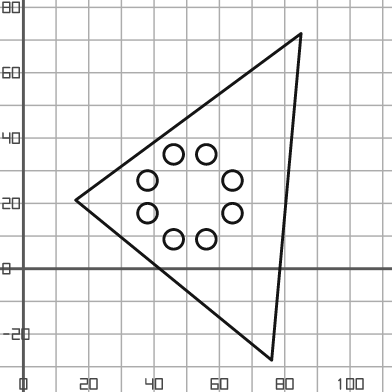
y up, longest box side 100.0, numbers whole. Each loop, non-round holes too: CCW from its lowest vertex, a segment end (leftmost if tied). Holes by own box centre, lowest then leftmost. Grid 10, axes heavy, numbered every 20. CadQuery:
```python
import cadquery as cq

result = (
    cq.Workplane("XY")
    .moveTo(76.0, -28.0)
    .lineTo(85.0, 72.0)
    .lineTo(16.0, 21.0)
    .close()
    .moveTo(46.0, 9.0)
    .circle(3.0)
    .moveTo(56.0, 9.0)
    .circle(3.0)
    .moveTo(38.0, 17.0)
    .circle(3.0)
    .moveTo(64.0, 17.0)
    .circle(3.0)
    .moveTo(38.0, 27.0)
    .circle(3.0)
    .moveTo(64.0, 27.0)
    .circle(3.0)
    .moveTo(46.0, 35.0)
    .circle(3.0)
    .moveTo(56.0, 35.0)
    .circle(3.0)
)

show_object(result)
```